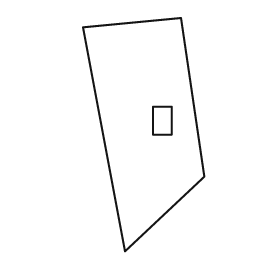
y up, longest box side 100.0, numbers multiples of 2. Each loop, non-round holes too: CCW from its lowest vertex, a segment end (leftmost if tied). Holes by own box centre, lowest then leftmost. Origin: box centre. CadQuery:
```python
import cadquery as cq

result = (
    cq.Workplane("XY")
    .moveTo(-8.0, -50.0)
    .lineTo(26.0, -18.0)
    .lineTo(16.0, 50.0)
    .lineTo(-26.0, 46.0)
    .close()
    .moveTo(4.0, 0.0)
    .lineTo(12.0, 0.0)
    .lineTo(12.0, 12.0)
    .lineTo(4.0, 12.0)
    .close()
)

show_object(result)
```